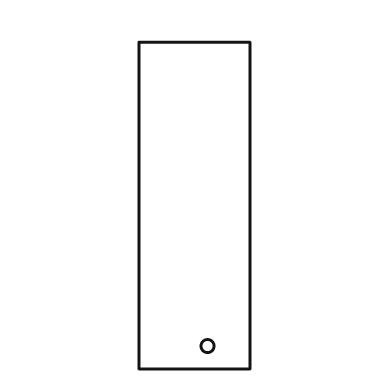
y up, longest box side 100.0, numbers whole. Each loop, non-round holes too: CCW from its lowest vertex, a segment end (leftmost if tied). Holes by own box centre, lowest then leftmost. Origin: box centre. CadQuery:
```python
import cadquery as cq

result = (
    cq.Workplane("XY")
    .moveTo(-17.0, -50.0)
    .lineTo(17.0, -50.0)
    .lineTo(17.0, 50.0)
    .lineTo(-17.0, 50.0)
    .close()
    .moveTo(4.0, -43.0)
    .circle(2.0)
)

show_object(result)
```